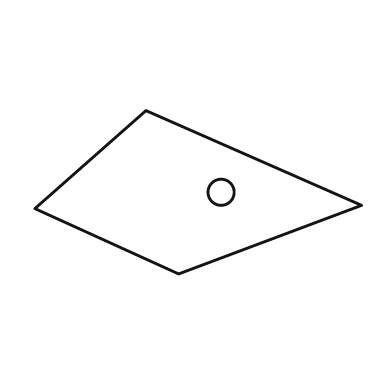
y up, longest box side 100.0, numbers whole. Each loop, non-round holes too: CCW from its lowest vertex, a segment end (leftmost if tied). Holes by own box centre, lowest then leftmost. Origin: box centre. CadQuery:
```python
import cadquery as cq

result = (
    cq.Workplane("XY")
    .moveTo(-6.0, -25.0)
    .lineTo(50.0, -4.0)
    .lineTo(-16.0, 25.0)
    .lineTo(-50.0, -5.0)
    .close()
    .moveTo(7.0, 0.0)
    .circle(4.0)
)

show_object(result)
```